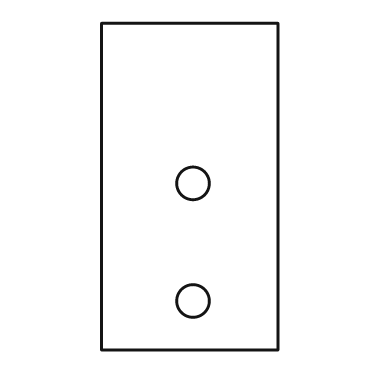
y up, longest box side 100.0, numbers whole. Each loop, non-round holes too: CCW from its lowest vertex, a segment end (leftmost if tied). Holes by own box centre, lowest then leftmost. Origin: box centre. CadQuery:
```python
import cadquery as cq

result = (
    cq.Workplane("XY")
    .moveTo(-27.0, -50.0)
    .lineTo(27.0, -50.0)
    .lineTo(27.0, 50.0)
    .lineTo(-27.0, 50.0)
    .close()
    .moveTo(1.0, -35.0)
    .circle(5.0)
    .moveTo(1.0, 1.0)
    .circle(5.0)
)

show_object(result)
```